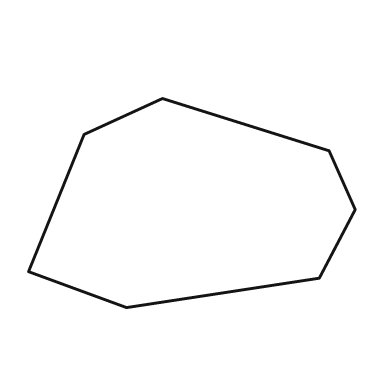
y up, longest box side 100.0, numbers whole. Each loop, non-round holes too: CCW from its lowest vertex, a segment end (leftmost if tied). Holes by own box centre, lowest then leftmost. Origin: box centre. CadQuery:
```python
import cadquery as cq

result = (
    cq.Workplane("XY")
    .moveTo(-20.0, -32.0)
    .lineTo(39.0, -23.0)
    .lineTo(50.0, -2.0)
    .lineTo(42.0, 16.0)
    .lineTo(-9.0, 32.0)
    .lineTo(-33.0, 21.0)
    .lineTo(-50.0, -21.0)
    .close()
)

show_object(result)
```